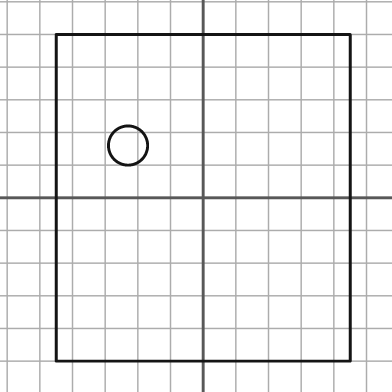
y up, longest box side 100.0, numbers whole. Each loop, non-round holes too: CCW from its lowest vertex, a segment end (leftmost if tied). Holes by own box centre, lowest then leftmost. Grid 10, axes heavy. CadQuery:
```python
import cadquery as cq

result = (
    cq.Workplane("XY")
    .moveTo(-45.0, -50.0)
    .lineTo(45.0, -50.0)
    .lineTo(45.0, 50.0)
    .lineTo(-45.0, 50.0)
    .close()
    .moveTo(-23.0, 16.0)
    .circle(6.0)
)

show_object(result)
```